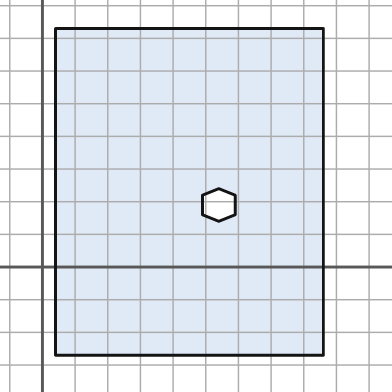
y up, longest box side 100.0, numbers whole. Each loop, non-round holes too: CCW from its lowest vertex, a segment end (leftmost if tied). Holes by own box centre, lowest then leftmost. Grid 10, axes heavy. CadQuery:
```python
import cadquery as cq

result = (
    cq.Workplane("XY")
    .moveTo(4.0, -27.0)
    .lineTo(86.0, -27.0)
    .lineTo(86.0, 73.0)
    .lineTo(4.0, 73.0)
    .close()
    .moveTo(54.0, 14.0)
    .lineTo(59.0, 16.0)
    .lineTo(59.0, 22.0)
    .lineTo(54.0, 24.0)
    .lineTo(49.0, 22.0)
    .lineTo(49.0, 16.0)
    .close()
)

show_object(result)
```